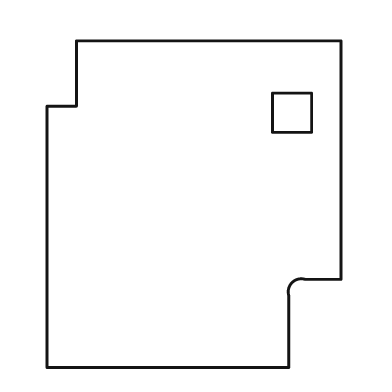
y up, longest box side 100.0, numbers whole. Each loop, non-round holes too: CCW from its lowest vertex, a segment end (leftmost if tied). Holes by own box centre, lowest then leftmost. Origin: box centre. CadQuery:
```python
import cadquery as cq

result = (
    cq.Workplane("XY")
    .moveTo(-45.0, -50.0)
    .lineTo(29.0, -50.0)
    .lineTo(29.0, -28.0)
    .threePointArc((30.0, -24.0), (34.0, -23.0))
    .lineTo(45.0, -23.0)
    .lineTo(45.0, 50.0)
    .lineTo(-36.0, 50.0)
    .lineTo(-36.0, 30.0)
    .lineTo(-45.0, 30.0)
    .close()
    .moveTo(24.0, 22.0)
    .lineTo(36.0, 22.0)
    .lineTo(36.0, 34.0)
    .lineTo(24.0, 34.0)
    .close()
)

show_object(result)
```